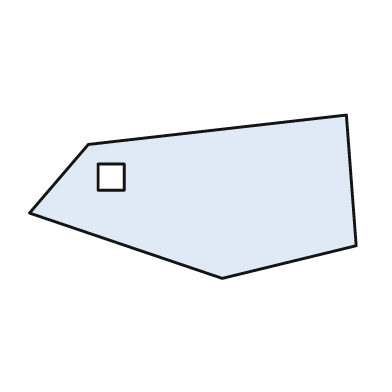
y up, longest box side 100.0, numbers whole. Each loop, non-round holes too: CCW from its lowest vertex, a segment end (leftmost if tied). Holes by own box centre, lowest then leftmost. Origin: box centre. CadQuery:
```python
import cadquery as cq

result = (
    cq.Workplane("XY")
    .moveTo(9.0, -25.0)
    .lineTo(50.0, -15.0)
    .lineTo(47.0, 25.0)
    .lineTo(-32.0, 16.0)
    .lineTo(-50.0, -5.0)
    .close()
    .moveTo(-29.0, 2.0)
    .lineTo(-21.0, 2.0)
    .lineTo(-21.0, 10.0)
    .lineTo(-29.0, 10.0)
    .close()
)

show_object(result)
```